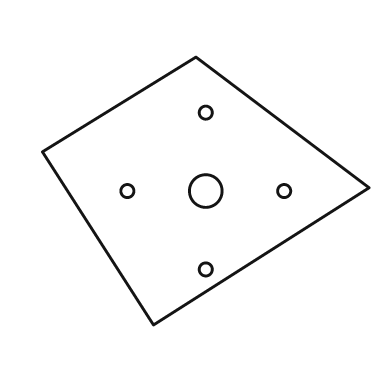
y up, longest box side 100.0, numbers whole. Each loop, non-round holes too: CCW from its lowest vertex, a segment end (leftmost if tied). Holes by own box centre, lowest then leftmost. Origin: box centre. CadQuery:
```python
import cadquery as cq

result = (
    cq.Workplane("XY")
    .moveTo(-16.0, -41.0)
    .lineTo(50.0, 1.0)
    .lineTo(-3.0, 41.0)
    .lineTo(-50.0, 12.0)
    .close()
    .moveTo(0.0, -24.0)
    .circle(2.0)
    .moveTo(-24.0, 0.0)
    .circle(2.0)
    .moveTo(0.0, 0.0)
    .circle(5.0)
    .moveTo(24.0, 0.0)
    .circle(2.0)
    .moveTo(0.0, 24.0)
    .circle(2.0)
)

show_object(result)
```